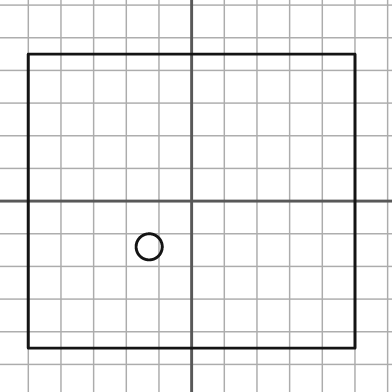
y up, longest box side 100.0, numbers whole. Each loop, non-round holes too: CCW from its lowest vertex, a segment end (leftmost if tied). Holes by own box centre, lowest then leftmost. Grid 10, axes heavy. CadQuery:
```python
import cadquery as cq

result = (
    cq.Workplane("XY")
    .moveTo(-50.0, -45.0)
    .lineTo(50.0, -45.0)
    .lineTo(50.0, 45.0)
    .lineTo(-50.0, 45.0)
    .close()
    .moveTo(-13.0, -14.0)
    .circle(4.0)
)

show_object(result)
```